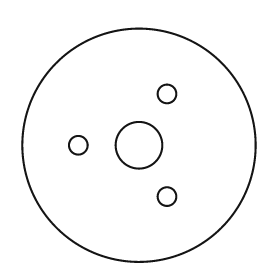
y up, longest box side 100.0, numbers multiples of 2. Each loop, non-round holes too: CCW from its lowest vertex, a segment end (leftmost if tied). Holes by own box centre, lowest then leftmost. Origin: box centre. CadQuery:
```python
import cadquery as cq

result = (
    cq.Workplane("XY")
    .moveTo(0.0, 0.0)
    .circle(50.0)
    .moveTo(12.0, -22.0)
    .circle(4.0)
    .moveTo(-26.0, 0.0)
    .circle(4.0)
    .moveTo(0.0, 0.0)
    .circle(10.0)
    .moveTo(12.0, 22.0)
    .circle(4.0)
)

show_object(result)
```